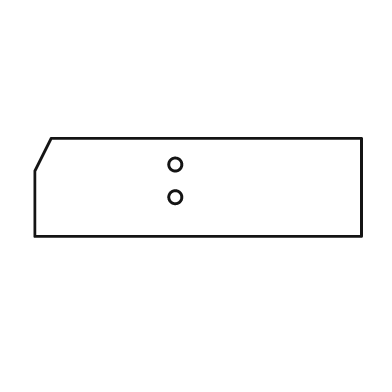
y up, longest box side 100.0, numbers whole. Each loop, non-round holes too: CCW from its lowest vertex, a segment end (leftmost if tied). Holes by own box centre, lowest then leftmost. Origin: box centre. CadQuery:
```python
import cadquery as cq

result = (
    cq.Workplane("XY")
    .moveTo(-50.0, -15.0)
    .lineTo(50.0, -15.0)
    .lineTo(50.0, 15.0)
    .lineTo(-45.0, 15.0)
    .lineTo(-50.0, 5.0)
    .close()
    .moveTo(-7.0, -3.0)
    .circle(2.0)
    .moveTo(-7.0, 7.0)
    .circle(2.0)
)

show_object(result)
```